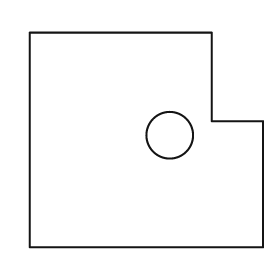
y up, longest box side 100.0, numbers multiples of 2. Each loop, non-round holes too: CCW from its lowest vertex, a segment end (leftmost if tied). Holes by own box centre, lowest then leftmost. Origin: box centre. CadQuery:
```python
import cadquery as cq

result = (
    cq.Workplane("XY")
    .moveTo(-50.0, -46.0)
    .lineTo(50.0, -46.0)
    .lineTo(50.0, 8.0)
    .lineTo(28.0, 8.0)
    .lineTo(28.0, 46.0)
    .lineTo(-50.0, 46.0)
    .close()
    .moveTo(10.0, 2.0)
    .circle(10.0)
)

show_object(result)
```